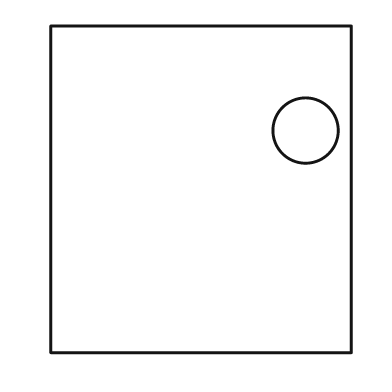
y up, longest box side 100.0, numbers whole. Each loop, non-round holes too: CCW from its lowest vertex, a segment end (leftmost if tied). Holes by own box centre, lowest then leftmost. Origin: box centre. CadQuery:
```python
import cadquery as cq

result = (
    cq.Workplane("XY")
    .moveTo(-46.0, -50.0)
    .lineTo(46.0, -50.0)
    .lineTo(46.0, 50.0)
    .lineTo(-46.0, 50.0)
    .close()
    .moveTo(32.0, 18.0)
    .circle(10.0)
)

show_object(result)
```